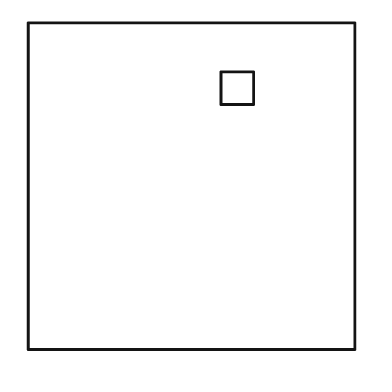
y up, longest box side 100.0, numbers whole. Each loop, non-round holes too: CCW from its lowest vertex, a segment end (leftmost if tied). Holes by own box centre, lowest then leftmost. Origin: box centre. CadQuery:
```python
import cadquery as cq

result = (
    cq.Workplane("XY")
    .moveTo(-50.0, -50.0)
    .lineTo(50.0, -50.0)
    .lineTo(50.0, 50.0)
    .lineTo(-50.0, 50.0)
    .close()
    .moveTo(9.0, 25.0)
    .lineTo(19.0, 25.0)
    .lineTo(19.0, 35.0)
    .lineTo(9.0, 35.0)
    .close()
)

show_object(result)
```